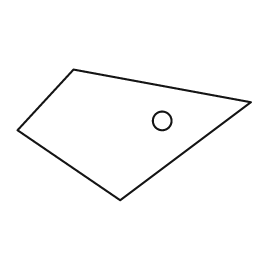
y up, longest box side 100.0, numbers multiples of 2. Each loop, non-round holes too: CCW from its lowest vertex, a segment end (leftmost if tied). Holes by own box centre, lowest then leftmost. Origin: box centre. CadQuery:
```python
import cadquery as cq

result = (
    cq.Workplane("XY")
    .moveTo(-6.0, -28.0)
    .lineTo(50.0, 14.0)
    .lineTo(-26.0, 28.0)
    .lineTo(-50.0, 2.0)
    .close()
    .moveTo(12.0, 6.0)
    .circle(4.0)
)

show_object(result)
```